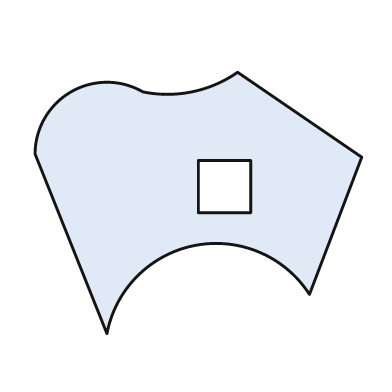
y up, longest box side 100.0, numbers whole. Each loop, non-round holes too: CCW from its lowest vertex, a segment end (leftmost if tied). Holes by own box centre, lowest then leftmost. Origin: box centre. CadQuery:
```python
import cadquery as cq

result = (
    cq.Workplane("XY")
    .moveTo(-28.0, -40.0)
    .threePointArc((-1.0, -13.0), (34.0, -28.0))
    .lineTo(50.0, 14.0)
    .lineTo(12.0, 40.0)
    .threePointArc((-2.0, 34.0), (-17.0, 34.0))
    .threePointArc((-39.0, 34.0), (-50.0, 15.0))
    .close()
    .moveTo(0.0, -3.0)
    .lineTo(16.0, -3.0)
    .lineTo(16.0, 13.0)
    .lineTo(0.0, 13.0)
    .close()
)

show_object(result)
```